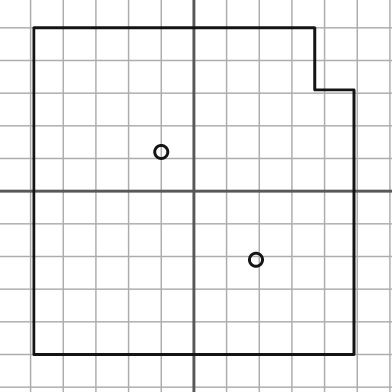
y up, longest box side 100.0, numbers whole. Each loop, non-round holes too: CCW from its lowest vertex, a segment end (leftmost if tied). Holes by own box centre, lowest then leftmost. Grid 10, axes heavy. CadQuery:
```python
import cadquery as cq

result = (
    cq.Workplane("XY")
    .moveTo(-49.0, -50.0)
    .lineTo(49.0, -50.0)
    .lineTo(49.0, 31.0)
    .lineTo(37.0, 31.0)
    .lineTo(37.0, 50.0)
    .lineTo(-49.0, 50.0)
    .close()
    .moveTo(19.0, -21.0)
    .circle(2.0)
    .moveTo(-10.0, 12.0)
    .circle(2.0)
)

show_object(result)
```